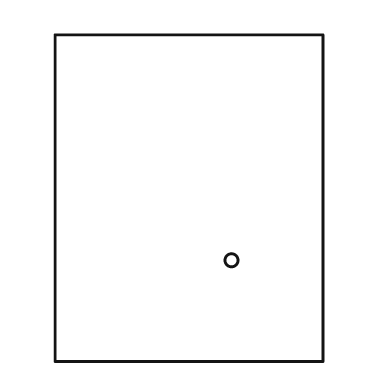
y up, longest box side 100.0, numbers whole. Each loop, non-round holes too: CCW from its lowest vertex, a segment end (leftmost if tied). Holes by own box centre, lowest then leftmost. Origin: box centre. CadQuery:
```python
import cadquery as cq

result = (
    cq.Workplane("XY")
    .moveTo(-41.0, -50.0)
    .lineTo(41.0, -50.0)
    .lineTo(41.0, 50.0)
    .lineTo(-41.0, 50.0)
    .close()
    .moveTo(13.0, -19.0)
    .circle(2.0)
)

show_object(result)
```